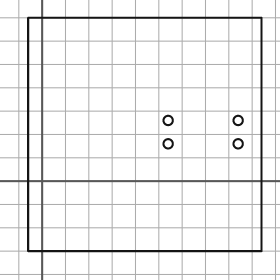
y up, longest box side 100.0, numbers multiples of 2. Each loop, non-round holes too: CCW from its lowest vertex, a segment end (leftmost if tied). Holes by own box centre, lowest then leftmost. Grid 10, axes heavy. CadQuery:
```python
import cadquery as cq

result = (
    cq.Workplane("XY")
    .moveTo(-6.0, -30.0)
    .lineTo(94.0, -30.0)
    .lineTo(94.0, 70.0)
    .lineTo(-6.0, 70.0)
    .close()
    .moveTo(54.0, 16.0)
    .circle(2.0)
    .moveTo(84.0, 16.0)
    .circle(2.0)
    .moveTo(54.0, 26.0)
    .circle(2.0)
    .moveTo(84.0, 26.0)
    .circle(2.0)
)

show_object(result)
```